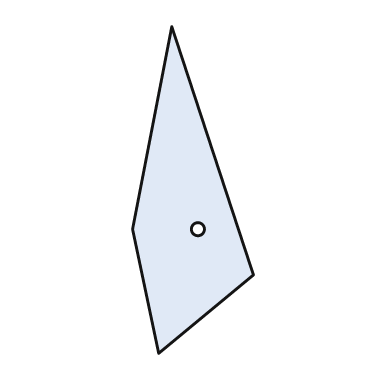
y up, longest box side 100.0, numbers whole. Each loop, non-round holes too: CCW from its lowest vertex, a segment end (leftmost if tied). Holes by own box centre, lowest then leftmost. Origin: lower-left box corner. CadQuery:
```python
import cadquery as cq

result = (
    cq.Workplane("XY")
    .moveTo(8.0, 0.0)
    .lineTo(37.0, 24.0)
    .lineTo(12.0, 100.0)
    .lineTo(0.0, 38.0)
    .close()
    .moveTo(20.0, 38.0)
    .circle(2.0)
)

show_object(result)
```